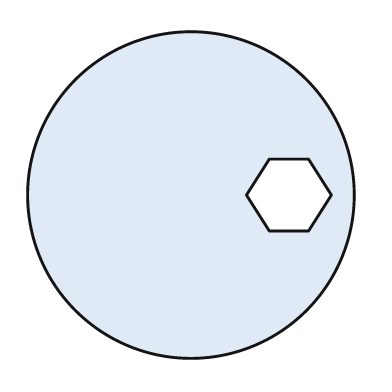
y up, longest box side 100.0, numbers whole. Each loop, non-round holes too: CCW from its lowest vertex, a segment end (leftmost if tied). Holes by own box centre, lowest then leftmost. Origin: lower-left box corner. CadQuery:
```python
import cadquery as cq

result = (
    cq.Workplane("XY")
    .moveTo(50.0, 50.0)
    .circle(50.0)
    .moveTo(74.0, 39.0)
    .lineTo(86.0, 39.0)
    .lineTo(93.0, 50.0)
    .lineTo(86.0, 61.0)
    .lineTo(74.0, 61.0)
    .lineTo(67.0, 50.0)
    .close()
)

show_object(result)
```